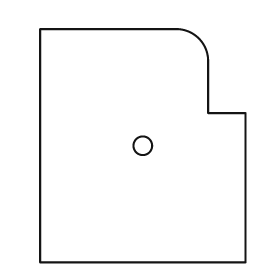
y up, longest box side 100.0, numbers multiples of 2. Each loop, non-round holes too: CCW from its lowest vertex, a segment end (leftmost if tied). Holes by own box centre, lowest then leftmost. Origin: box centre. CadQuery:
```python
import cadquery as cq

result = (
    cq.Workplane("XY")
    .moveTo(-44.0, -50.0)
    .lineTo(44.0, -50.0)
    .lineTo(44.0, 14.0)
    .lineTo(28.0, 14.0)
    .lineTo(28.0, 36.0)
    .threePointArc((24.0, 46.0), (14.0, 50.0))
    .lineTo(-44.0, 50.0)
    .close()
    .moveTo(0.0, 0.0)
    .circle(4.0)
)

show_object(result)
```